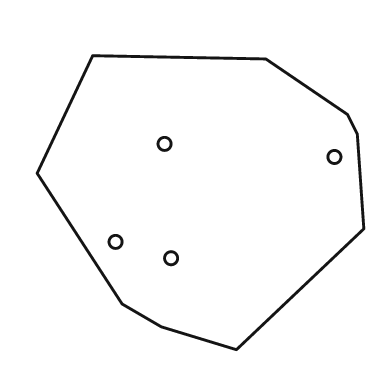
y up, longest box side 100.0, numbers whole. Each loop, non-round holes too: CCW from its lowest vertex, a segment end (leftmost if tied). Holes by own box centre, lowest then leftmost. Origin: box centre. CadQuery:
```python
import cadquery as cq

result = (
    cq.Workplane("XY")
    .moveTo(11.0, -45.0)
    .lineTo(50.0, -8.0)
    .lineTo(48.0, 21.0)
    .lineTo(45.0, 27.0)
    .lineTo(20.0, 44.0)
    .lineTo(-33.0, 45.0)
    .lineTo(-50.0, 9.0)
    .lineTo(-24.0, -31.0)
    .lineTo(-12.0, -38.0)
    .close()
    .moveTo(-9.0, -17.0)
    .circle(2.0)
    .moveTo(-26.0, -12.0)
    .circle(2.0)
    .moveTo(41.0, 14.0)
    .circle(2.0)
    .moveTo(-11.0, 18.0)
    .circle(2.0)
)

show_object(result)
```